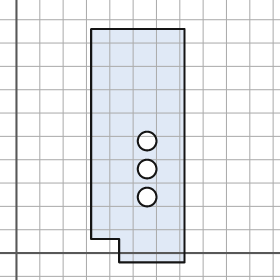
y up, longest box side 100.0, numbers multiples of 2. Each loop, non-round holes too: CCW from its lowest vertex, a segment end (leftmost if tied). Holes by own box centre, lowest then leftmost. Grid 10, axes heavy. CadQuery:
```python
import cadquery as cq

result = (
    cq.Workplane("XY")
    .moveTo(44.0, -4.0)
    .lineTo(72.0, -4.0)
    .lineTo(72.0, 96.0)
    .lineTo(32.0, 96.0)
    .lineTo(32.0, 6.0)
    .lineTo(44.0, 6.0)
    .close()
    .moveTo(56.0, 24.0)
    .circle(4.0)
    .moveTo(56.0, 36.0)
    .circle(4.0)
    .moveTo(56.0, 48.0)
    .circle(4.0)
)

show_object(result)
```